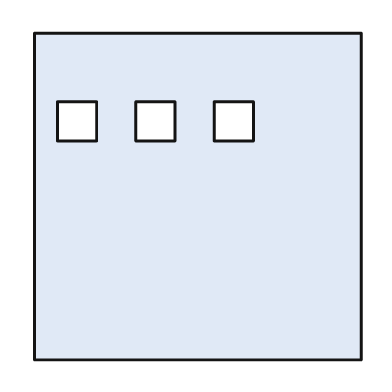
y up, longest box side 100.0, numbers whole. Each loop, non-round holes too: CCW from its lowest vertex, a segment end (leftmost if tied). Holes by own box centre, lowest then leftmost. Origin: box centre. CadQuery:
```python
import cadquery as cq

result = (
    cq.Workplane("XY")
    .moveTo(-50.0, -50.0)
    .lineTo(50.0, -50.0)
    .lineTo(50.0, 50.0)
    .lineTo(-50.0, 50.0)
    .close()
    .moveTo(-43.0, 17.0)
    .lineTo(-31.0, 17.0)
    .lineTo(-31.0, 29.0)
    .lineTo(-43.0, 29.0)
    .close()
    .moveTo(-19.0, 17.0)
    .lineTo(-7.0, 17.0)
    .lineTo(-7.0, 29.0)
    .lineTo(-19.0, 29.0)
    .close()
    .moveTo(5.0, 17.0)
    .lineTo(17.0, 17.0)
    .lineTo(17.0, 29.0)
    .lineTo(5.0, 29.0)
    .close()
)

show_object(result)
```